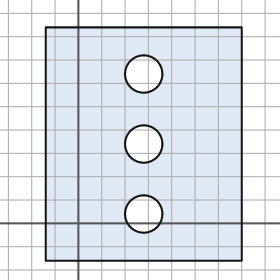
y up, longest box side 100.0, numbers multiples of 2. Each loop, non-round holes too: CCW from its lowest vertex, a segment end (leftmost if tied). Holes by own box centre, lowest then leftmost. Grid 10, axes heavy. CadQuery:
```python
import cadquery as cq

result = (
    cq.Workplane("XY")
    .moveTo(-14.0, -16.0)
    .lineTo(70.0, -16.0)
    .lineTo(70.0, 84.0)
    .lineTo(-14.0, 84.0)
    .close()
    .moveTo(28.0, 4.0)
    .circle(8.0)
    .moveTo(28.0, 34.0)
    .circle(8.0)
    .moveTo(28.0, 64.0)
    .circle(8.0)
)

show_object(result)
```